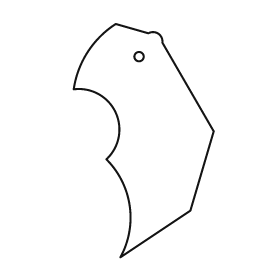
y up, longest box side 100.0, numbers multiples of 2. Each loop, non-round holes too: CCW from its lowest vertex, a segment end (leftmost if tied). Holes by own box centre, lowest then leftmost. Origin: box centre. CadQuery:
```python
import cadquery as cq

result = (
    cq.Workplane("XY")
    .moveTo(-10.0, -50.0)
    .lineTo(20.0, -30.0)
    .lineTo(30.0, 4.0)
    .lineTo(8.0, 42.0)
    .threePointArc((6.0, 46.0), (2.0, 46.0))
    .lineTo(-12.0, 50.0)
    .threePointArc((-24.0, 38.0), (-30.0, 22.0))
    .threePointArc((-12.0, 12.0), (-16.0, -8.0))
    .threePointArc((-6.0, -28.0), (-10.0, -50.0))
    .close()
    .moveTo(-2.0, 36.0)
    .circle(2.0)
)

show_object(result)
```